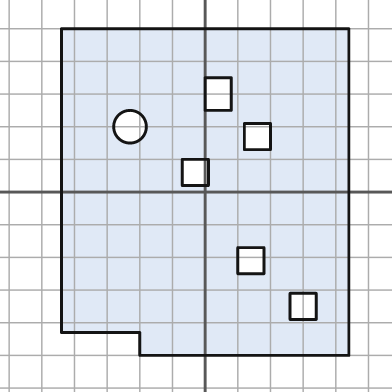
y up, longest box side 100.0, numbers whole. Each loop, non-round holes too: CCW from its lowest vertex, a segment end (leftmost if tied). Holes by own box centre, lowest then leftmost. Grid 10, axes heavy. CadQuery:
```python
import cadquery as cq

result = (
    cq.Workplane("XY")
    .moveTo(-20.0, -50.0)
    .lineTo(44.0, -50.0)
    .lineTo(44.0, 50.0)
    .lineTo(-44.0, 50.0)
    .lineTo(-44.0, -43.0)
    .lineTo(-20.0, -43.0)
    .close()
    .moveTo(26.0, -39.0)
    .lineTo(34.0, -39.0)
    .lineTo(34.0, -31.0)
    .lineTo(26.0, -31.0)
    .close()
    .moveTo(10.0, -25.0)
    .lineTo(18.0, -25.0)
    .lineTo(18.0, -17.0)
    .lineTo(10.0, -17.0)
    .close()
    .moveTo(-7.0, 2.0)
    .lineTo(1.0, 2.0)
    .lineTo(1.0, 10.0)
    .lineTo(-7.0, 10.0)
    .close()
    .moveTo(12.0, 13.0)
    .lineTo(20.0, 13.0)
    .lineTo(20.0, 21.0)
    .lineTo(12.0, 21.0)
    .close()
    .moveTo(-23.0, 20.0)
    .circle(5.0)
    .moveTo(0.0, 25.0)
    .lineTo(8.0, 25.0)
    .lineTo(8.0, 35.0)
    .lineTo(0.0, 35.0)
    .close()
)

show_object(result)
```